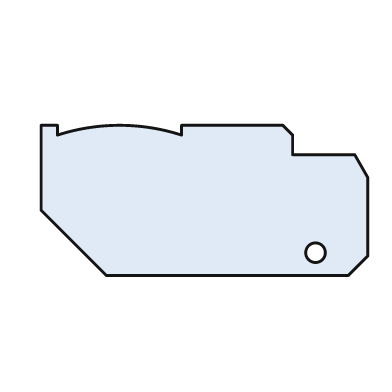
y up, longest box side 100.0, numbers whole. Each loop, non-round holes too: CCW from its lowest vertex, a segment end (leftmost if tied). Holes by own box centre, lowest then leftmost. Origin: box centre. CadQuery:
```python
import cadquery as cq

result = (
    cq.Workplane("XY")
    .moveTo(-30.0, -23.0)
    .lineTo(44.0, -23.0)
    .lineTo(50.0, -17.0)
    .lineTo(50.0, 7.0)
    .lineTo(46.0, 14.0)
    .lineTo(27.0, 14.0)
    .lineTo(27.0, 20.0)
    .lineTo(24.0, 23.0)
    .lineTo(-7.0, 23.0)
    .lineTo(-7.0, 20.0)
    .threePointArc((-26.0, 23.0), (-45.0, 20.0))
    .lineTo(-45.0, 23.0)
    .lineTo(-50.0, 23.0)
    .lineTo(-50.0, -3.0)
    .close()
    .moveTo(34.0, -16.0)
    .circle(3.0)
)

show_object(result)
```